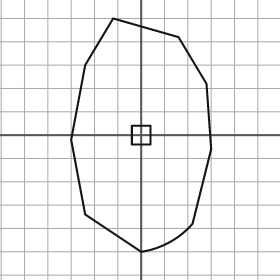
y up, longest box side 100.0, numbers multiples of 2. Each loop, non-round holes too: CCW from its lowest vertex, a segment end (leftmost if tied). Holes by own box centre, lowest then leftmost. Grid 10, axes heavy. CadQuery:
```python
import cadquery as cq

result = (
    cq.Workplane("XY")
    .moveTo(0.0, -50.0)
    .threePointArc((12.0, -46.0), (22.0, -38.0))
    .lineTo(30.0, -6.0)
    .lineTo(28.0, 22.0)
    .lineTo(16.0, 42.0)
    .lineTo(-12.0, 50.0)
    .lineTo(-24.0, 30.0)
    .lineTo(-30.0, -2.0)
    .lineTo(-24.0, -34.0)
    .close()
    .moveTo(-4.0, -4.0)
    .lineTo(4.0, -4.0)
    .lineTo(4.0, 4.0)
    .lineTo(-4.0, 4.0)
    .close()
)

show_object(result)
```